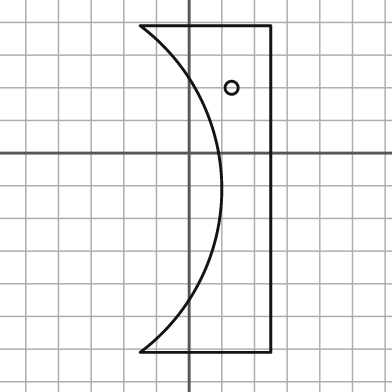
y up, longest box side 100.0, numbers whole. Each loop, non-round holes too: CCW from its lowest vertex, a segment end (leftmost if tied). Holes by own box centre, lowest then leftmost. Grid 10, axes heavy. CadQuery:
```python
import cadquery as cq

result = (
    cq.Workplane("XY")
    .moveTo(-15.0, -61.0)
    .lineTo(25.0, -61.0)
    .lineTo(25.0, 39.0)
    .lineTo(-15.0, 39.0)
    .threePointArc((10.0, -11.0), (-15.0, -61.0))
    .close()
    .moveTo(13.0, 20.0)
    .circle(2.0)
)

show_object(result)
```